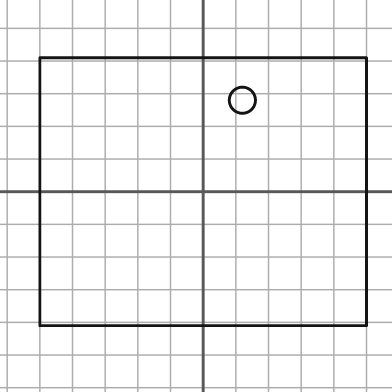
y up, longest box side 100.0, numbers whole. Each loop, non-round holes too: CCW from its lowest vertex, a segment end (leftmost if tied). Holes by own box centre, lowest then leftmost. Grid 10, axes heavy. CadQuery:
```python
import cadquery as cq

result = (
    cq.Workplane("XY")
    .moveTo(-50.0, -41.0)
    .lineTo(50.0, -41.0)
    .lineTo(50.0, 41.0)
    .lineTo(-50.0, 41.0)
    .close()
    .moveTo(12.0, 28.0)
    .circle(4.0)
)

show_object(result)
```